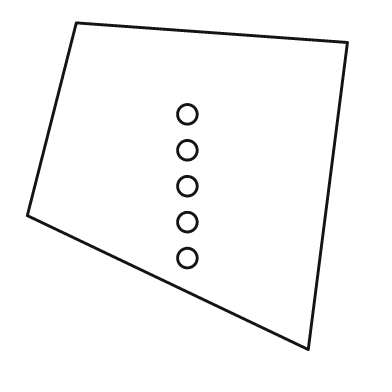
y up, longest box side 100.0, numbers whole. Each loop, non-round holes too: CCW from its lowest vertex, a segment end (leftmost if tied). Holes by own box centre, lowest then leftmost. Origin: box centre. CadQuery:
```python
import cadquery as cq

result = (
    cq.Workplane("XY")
    .moveTo(37.0, -50.0)
    .lineTo(49.0, 44.0)
    .lineTo(-34.0, 50.0)
    .lineTo(-49.0, -9.0)
    .close()
    .moveTo(0.0, -22.0)
    .circle(3.0)
    .moveTo(0.0, -11.0)
    .circle(3.0)
    .moveTo(0.0, 0.0)
    .circle(3.0)
    .moveTo(0.0, 11.0)
    .circle(3.0)
    .moveTo(0.0, 22.0)
    .circle(3.0)
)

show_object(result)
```